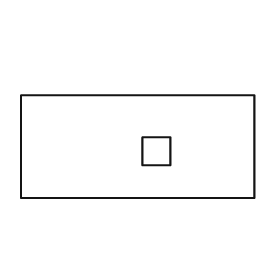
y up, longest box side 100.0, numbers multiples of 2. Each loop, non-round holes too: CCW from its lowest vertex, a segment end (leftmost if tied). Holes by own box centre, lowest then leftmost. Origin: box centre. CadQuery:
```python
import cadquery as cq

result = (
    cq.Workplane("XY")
    .moveTo(-50.0, -22.0)
    .lineTo(50.0, -22.0)
    .lineTo(50.0, 22.0)
    .lineTo(-50.0, 22.0)
    .close()
    .moveTo(2.0, -8.0)
    .lineTo(14.0, -8.0)
    .lineTo(14.0, 4.0)
    .lineTo(2.0, 4.0)
    .close()
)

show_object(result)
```